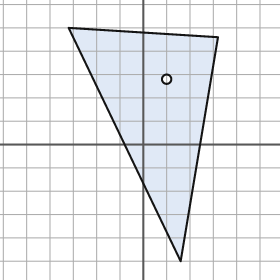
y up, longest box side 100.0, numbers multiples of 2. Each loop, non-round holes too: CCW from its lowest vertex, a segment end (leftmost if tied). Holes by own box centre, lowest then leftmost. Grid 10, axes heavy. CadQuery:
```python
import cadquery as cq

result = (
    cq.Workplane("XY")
    .moveTo(16.0, -50.0)
    .lineTo(32.0, 46.0)
    .lineTo(-32.0, 50.0)
    .close()
    .moveTo(10.0, 28.0)
    .circle(2.0)
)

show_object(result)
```